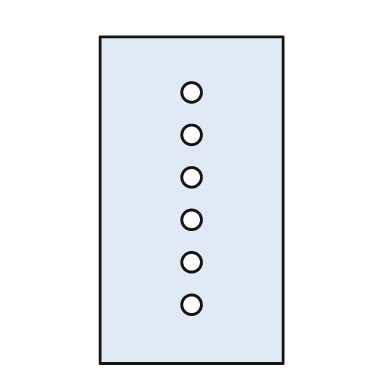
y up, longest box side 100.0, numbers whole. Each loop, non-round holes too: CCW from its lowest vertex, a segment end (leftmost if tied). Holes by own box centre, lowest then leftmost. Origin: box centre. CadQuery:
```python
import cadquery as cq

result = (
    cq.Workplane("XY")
    .moveTo(-28.0, -50.0)
    .lineTo(28.0, -50.0)
    .lineTo(28.0, 50.0)
    .lineTo(-28.0, 50.0)
    .close()
    .moveTo(0.0, -32.0)
    .circle(3.0)
    .moveTo(0.0, -19.0)
    .circle(3.0)
    .moveTo(0.0, -6.0)
    .circle(3.0)
    .moveTo(0.0, 7.0)
    .circle(3.0)
    .moveTo(0.0, 20.0)
    .circle(3.0)
    .moveTo(0.0, 33.0)
    .circle(3.0)
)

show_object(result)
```